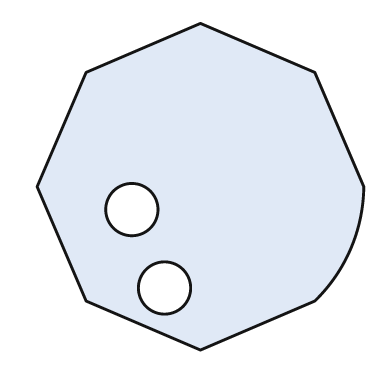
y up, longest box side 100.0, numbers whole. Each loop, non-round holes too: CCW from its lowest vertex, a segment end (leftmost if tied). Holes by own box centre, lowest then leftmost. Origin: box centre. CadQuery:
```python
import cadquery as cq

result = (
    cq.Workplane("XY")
    .moveTo(0.0, -50.0)
    .lineTo(35.0, -35.0)
    .threePointArc((46.0, -19.0), (50.0, 0.0))
    .lineTo(35.0, 35.0)
    .lineTo(0.0, 50.0)
    .lineTo(-35.0, 35.0)
    .lineTo(-50.0, 0.0)
    .lineTo(-35.0, -35.0)
    .close()
    .moveTo(-11.0, -31.0)
    .circle(8.0)
    .moveTo(-21.0, -7.0)
    .circle(8.0)
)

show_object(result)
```